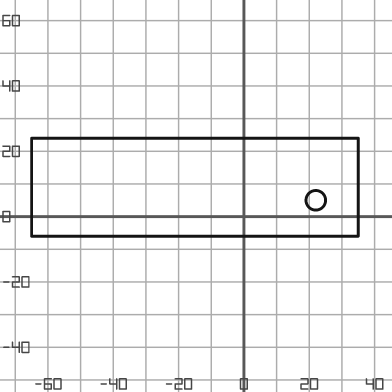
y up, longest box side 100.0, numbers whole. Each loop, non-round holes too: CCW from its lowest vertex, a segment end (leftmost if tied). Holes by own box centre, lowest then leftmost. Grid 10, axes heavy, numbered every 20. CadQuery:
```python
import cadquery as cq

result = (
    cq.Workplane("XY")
    .moveTo(-65.0, -6.0)
    .lineTo(35.0, -6.0)
    .lineTo(35.0, 24.0)
    .lineTo(-65.0, 24.0)
    .close()
    .moveTo(22.0, 5.0)
    .circle(3.0)
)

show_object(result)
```